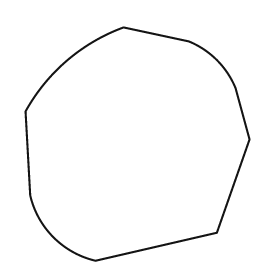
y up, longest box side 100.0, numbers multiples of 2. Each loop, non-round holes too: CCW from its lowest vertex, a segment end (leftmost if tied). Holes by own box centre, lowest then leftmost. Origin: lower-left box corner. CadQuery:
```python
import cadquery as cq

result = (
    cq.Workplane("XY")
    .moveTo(30.0, 0.0)
    .lineTo(82.0, 12.0)
    .lineTo(96.0, 52.0)
    .lineTo(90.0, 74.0)
    .threePointArc((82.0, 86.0), (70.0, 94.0))
    .lineTo(42.0, 100.0)
    .threePointArc((18.0, 86.0), (0.0, 64.0))
    .lineTo(2.0, 28.0)
    .threePointArc((12.0, 10.0), (30.0, 0.0))
    .close()
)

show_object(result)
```